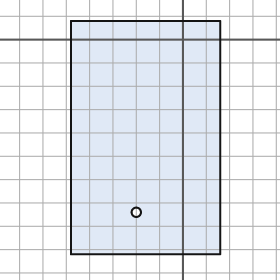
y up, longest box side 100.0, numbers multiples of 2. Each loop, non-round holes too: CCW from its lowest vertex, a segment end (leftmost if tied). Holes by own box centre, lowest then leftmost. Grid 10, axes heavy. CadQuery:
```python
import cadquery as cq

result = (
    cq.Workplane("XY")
    .moveTo(-48.0, -92.0)
    .lineTo(16.0, -92.0)
    .lineTo(16.0, 8.0)
    .lineTo(-48.0, 8.0)
    .close()
    .moveTo(-20.0, -74.0)
    .circle(2.0)
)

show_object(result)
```